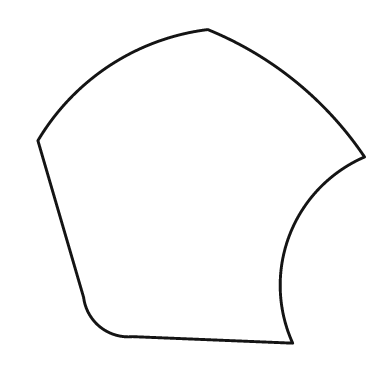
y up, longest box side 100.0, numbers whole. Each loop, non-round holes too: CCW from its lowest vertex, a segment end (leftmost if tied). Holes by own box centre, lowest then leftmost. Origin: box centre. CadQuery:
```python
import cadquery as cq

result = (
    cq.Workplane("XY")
    .moveTo(28.0, -48.0)
    .threePointArc((27.0, -15.0), (50.0, 9.0))
    .threePointArc((29.0, 32.0), (2.0, 48.0))
    .threePointArc((-28.0, 37.0), (-50.0, 14.0))
    .lineTo(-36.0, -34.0)
    .threePointArc((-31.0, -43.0), (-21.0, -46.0))
    .close()
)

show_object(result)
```